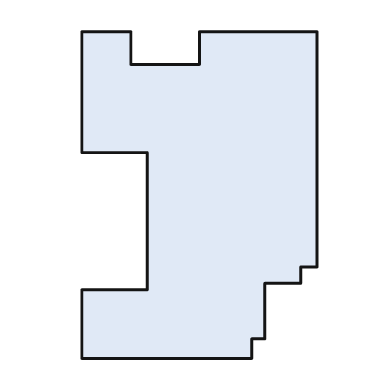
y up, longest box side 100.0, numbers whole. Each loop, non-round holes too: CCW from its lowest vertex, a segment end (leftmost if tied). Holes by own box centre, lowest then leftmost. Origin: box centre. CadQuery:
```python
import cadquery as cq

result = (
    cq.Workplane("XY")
    .moveTo(-36.0, -50.0)
    .lineTo(16.0, -50.0)
    .lineTo(16.0, -44.0)
    .lineTo(20.0, -44.0)
    .lineTo(20.0, -27.0)
    .lineTo(31.0, -27.0)
    .lineTo(31.0, -22.0)
    .lineTo(36.0, -22.0)
    .lineTo(36.0, 50.0)
    .lineTo(0.0, 50.0)
    .lineTo(0.0, 40.0)
    .lineTo(-21.0, 40.0)
    .lineTo(-21.0, 50.0)
    .lineTo(-36.0, 50.0)
    .lineTo(-36.0, 13.0)
    .lineTo(-16.0, 13.0)
    .lineTo(-16.0, -29.0)
    .lineTo(-36.0, -29.0)
    .close()
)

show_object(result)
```